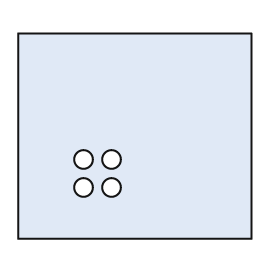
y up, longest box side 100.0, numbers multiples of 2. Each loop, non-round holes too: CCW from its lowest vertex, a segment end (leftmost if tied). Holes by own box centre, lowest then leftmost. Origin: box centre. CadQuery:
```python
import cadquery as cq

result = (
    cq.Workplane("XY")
    .moveTo(-50.0, -44.0)
    .lineTo(50.0, -44.0)
    .lineTo(50.0, 44.0)
    .lineTo(-50.0, 44.0)
    .close()
    .moveTo(-22.0, -22.0)
    .circle(4.0)
    .moveTo(-10.0, -22.0)
    .circle(4.0)
    .moveTo(-22.0, -10.0)
    .circle(4.0)
    .moveTo(-10.0, -10.0)
    .circle(4.0)
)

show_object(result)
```